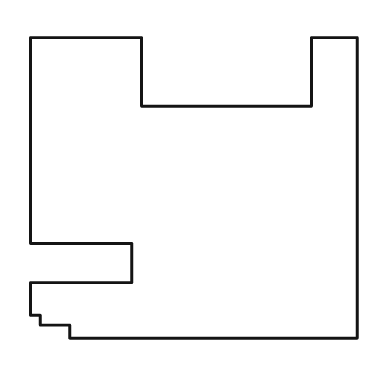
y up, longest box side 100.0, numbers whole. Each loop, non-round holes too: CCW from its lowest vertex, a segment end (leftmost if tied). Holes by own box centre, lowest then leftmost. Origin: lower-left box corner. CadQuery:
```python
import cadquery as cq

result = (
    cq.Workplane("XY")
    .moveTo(12.0, 0.0)
    .lineTo(100.0, 0.0)
    .lineTo(100.0, 92.0)
    .lineTo(86.0, 92.0)
    .lineTo(86.0, 71.0)
    .lineTo(34.0, 71.0)
    .lineTo(34.0, 92.0)
    .lineTo(0.0, 92.0)
    .lineTo(0.0, 29.0)
    .lineTo(31.0, 29.0)
    .lineTo(31.0, 17.0)
    .lineTo(0.0, 17.0)
    .lineTo(0.0, 7.0)
    .lineTo(3.0, 7.0)
    .lineTo(3.0, 4.0)
    .lineTo(12.0, 4.0)
    .close()
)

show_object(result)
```